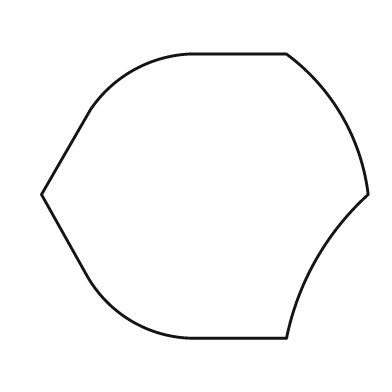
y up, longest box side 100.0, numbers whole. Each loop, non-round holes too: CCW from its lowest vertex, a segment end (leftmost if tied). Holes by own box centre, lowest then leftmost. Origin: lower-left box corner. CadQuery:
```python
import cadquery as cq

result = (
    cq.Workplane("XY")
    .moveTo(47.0, 0.0)
    .lineTo(75.0, 0.0)
    .threePointArc((84.0, 24.0), (100.0, 44.0))
    .threePointArc((92.0, 68.0), (75.0, 87.0))
    .lineTo(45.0, 87.0)
    .threePointArc((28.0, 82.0), (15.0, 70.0))
    .lineTo(0.0, 44.0)
    .lineTo(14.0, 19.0)
    .threePointArc((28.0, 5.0), (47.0, 0.0))
    .close()
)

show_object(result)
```